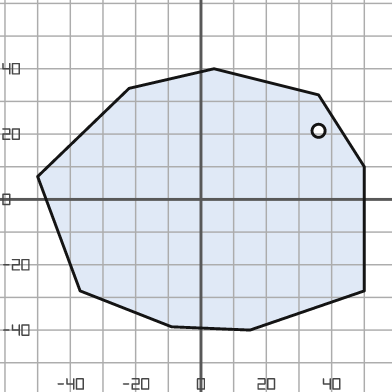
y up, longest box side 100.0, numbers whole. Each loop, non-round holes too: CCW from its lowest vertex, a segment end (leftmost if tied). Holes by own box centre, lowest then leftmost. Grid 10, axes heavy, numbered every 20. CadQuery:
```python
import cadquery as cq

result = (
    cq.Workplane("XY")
    .moveTo(15.0, -40.0)
    .lineTo(50.0, -28.0)
    .lineTo(50.0, 10.0)
    .lineTo(36.0, 32.0)
    .lineTo(4.0, 40.0)
    .lineTo(-22.0, 34.0)
    .lineTo(-50.0, 7.0)
    .lineTo(-37.0, -28.0)
    .lineTo(-9.0, -39.0)
    .close()
    .moveTo(36.0, 21.0)
    .circle(2.0)
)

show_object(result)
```